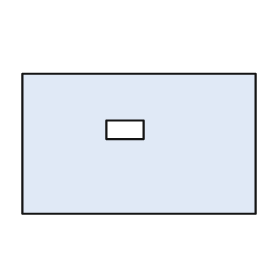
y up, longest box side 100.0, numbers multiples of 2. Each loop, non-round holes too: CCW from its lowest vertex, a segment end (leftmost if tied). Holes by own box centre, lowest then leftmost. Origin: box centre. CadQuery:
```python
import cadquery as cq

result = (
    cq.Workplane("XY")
    .moveTo(-50.0, -30.0)
    .lineTo(50.0, -30.0)
    .lineTo(50.0, 30.0)
    .lineTo(-50.0, 30.0)
    .close()
    .moveTo(-14.0, 2.0)
    .lineTo(2.0, 2.0)
    .lineTo(2.0, 10.0)
    .lineTo(-14.0, 10.0)
    .close()
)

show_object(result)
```